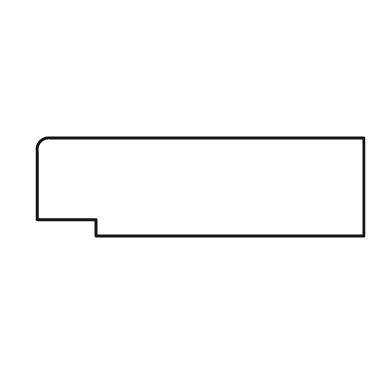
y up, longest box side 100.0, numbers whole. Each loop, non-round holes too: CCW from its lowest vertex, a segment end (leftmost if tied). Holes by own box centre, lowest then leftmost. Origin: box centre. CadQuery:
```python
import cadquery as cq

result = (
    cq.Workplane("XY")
    .moveTo(-32.0, -15.0)
    .lineTo(50.0, -15.0)
    .lineTo(50.0, 15.0)
    .lineTo(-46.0, 15.0)
    .threePointArc((-49.0, 14.0), (-50.0, 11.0))
    .lineTo(-50.0, -10.0)
    .lineTo(-32.0, -10.0)
    .close()
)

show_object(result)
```